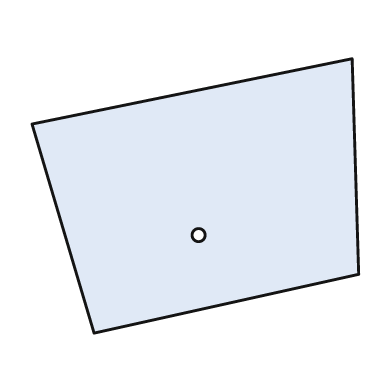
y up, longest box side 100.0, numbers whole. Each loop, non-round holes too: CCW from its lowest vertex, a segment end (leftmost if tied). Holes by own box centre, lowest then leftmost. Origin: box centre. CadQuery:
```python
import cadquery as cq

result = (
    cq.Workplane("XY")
    .moveTo(-31.0, -42.0)
    .lineTo(50.0, -24.0)
    .lineTo(48.0, 42.0)
    .lineTo(-50.0, 22.0)
    .close()
    .moveTo(1.0, -12.0)
    .circle(2.0)
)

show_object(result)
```